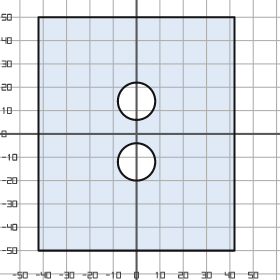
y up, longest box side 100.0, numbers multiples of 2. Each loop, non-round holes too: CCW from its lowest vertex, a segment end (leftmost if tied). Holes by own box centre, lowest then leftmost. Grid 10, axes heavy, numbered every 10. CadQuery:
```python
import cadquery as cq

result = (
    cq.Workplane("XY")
    .moveTo(-42.0, -50.0)
    .lineTo(42.0, -50.0)
    .lineTo(42.0, 50.0)
    .lineTo(-42.0, 50.0)
    .close()
    .moveTo(0.0, -12.0)
    .circle(8.0)
    .moveTo(0.0, 14.0)
    .circle(8.0)
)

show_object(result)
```